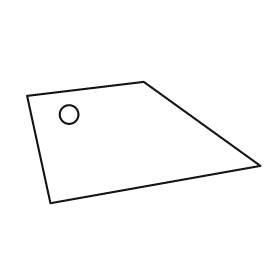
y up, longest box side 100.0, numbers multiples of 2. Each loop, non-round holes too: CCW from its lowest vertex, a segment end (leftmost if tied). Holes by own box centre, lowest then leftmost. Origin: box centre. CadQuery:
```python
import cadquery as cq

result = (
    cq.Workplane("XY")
    .moveTo(-40.0, -26.0)
    .lineTo(50.0, -10.0)
    .lineTo(0.0, 26.0)
    .lineTo(-50.0, 20.0)
    .close()
    .moveTo(-32.0, 12.0)
    .circle(4.0)
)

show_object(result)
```